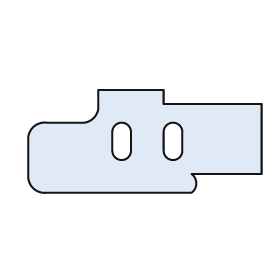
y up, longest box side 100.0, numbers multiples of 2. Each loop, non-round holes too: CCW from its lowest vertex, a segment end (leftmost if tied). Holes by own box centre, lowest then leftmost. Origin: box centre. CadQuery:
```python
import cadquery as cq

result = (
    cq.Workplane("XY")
    .moveTo(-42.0, -22.0)
    .lineTo(20.0, -22.0)
    .threePointArc((22.0, -18.0), (20.0, -14.0))
    .lineTo(50.0, -14.0)
    .lineTo(50.0, 16.0)
    .lineTo(8.0, 16.0)
    .lineTo(8.0, 22.0)
    .lineTo(-20.0, 22.0)
    .lineTo(-20.0, 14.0)
    .threePointArc((-22.0, 10.0), (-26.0, 8.0))
    .lineTo(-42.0, 8.0)
    .threePointArc((-48.0, 6.0), (-50.0, 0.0))
    .lineTo(-50.0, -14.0)
    .threePointArc((-48.0, -20.0), (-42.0, -22.0))
    .close()
    .moveTo(-14.0, -4.0)
    .threePointArc((-10.0, -8.0), (-6.0, -4.0))
    .lineTo(-6.0, 4.0)
    .threePointArc((-10.0, 8.0), (-14.0, 4.0))
    .close()
    .moveTo(8.0, -4.0)
    .threePointArc((12.0, -8.0), (16.0, -4.0))
    .lineTo(16.0, 4.0)
    .threePointArc((12.0, 8.0), (8.0, 4.0))
    .close()
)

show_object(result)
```